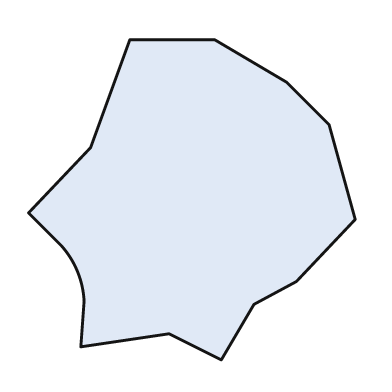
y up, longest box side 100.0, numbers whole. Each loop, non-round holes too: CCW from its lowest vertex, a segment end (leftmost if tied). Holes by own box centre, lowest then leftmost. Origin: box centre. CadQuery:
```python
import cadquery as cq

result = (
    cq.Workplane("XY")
    .moveTo(9.0, -49.0)
    .lineTo(19.0, -32.0)
    .lineTo(32.0, -25.0)
    .lineTo(50.0, -6.0)
    .lineTo(42.0, 23.0)
    .lineTo(29.0, 36.0)
    .lineTo(7.0, 49.0)
    .lineTo(-19.0, 49.0)
    .lineTo(-31.0, 16.0)
    .lineTo(-50.0, -4.0)
    .lineTo(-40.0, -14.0)
    .threePointArc((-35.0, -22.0), (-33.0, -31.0))
    .lineTo(-34.0, -45.0)
    .lineTo(-7.0, -41.0)
    .close()
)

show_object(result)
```